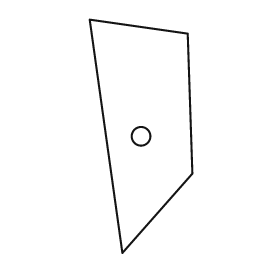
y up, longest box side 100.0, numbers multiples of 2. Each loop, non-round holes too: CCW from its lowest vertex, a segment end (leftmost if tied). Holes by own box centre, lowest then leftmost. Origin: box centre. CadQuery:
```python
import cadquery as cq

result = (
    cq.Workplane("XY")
    .moveTo(-8.0, -50.0)
    .lineTo(22.0, -16.0)
    .lineTo(20.0, 44.0)
    .lineTo(-22.0, 50.0)
    .close()
    .moveTo(0.0, 0.0)
    .circle(4.0)
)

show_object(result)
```